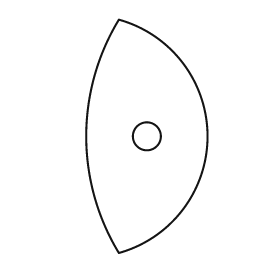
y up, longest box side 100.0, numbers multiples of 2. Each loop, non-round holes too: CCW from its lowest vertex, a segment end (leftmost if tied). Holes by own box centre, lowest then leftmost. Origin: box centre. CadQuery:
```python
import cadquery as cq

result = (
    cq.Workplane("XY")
    .moveTo(-12.0, -50.0)
    .threePointArc((26.0, 0.0), (-12.0, 50.0))
    .threePointArc((-26.0, 0.0), (-12.0, -50.0))
    .close()
    .moveTo(0.0, 0.0)
    .circle(6.0)
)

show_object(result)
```